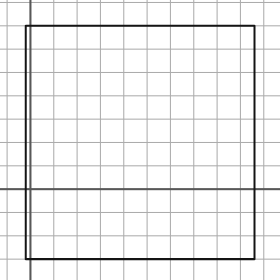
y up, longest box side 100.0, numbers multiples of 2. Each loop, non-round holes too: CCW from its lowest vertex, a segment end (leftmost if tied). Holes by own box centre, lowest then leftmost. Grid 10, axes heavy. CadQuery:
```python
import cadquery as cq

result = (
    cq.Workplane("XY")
    .moveTo(-2.0, -30.0)
    .lineTo(96.0, -30.0)
    .lineTo(96.0, 70.0)
    .lineTo(-2.0, 70.0)
    .close()
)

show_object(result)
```